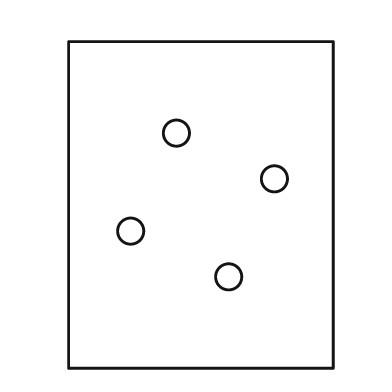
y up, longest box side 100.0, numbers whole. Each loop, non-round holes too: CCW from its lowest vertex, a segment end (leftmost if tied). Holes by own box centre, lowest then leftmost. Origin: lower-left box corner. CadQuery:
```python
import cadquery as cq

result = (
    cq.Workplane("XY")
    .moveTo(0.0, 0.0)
    .lineTo(81.0, 0.0)
    .lineTo(81.0, 100.0)
    .lineTo(0.0, 100.0)
    .close()
    .moveTo(49.0, 28.0)
    .circle(4.0)
    .moveTo(19.0, 42.0)
    .circle(4.0)
    .moveTo(63.0, 58.0)
    .circle(4.0)
    .moveTo(33.0, 72.0)
    .circle(4.0)
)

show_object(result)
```